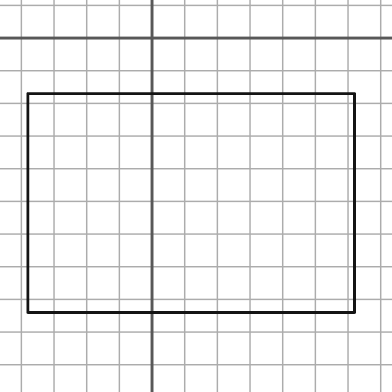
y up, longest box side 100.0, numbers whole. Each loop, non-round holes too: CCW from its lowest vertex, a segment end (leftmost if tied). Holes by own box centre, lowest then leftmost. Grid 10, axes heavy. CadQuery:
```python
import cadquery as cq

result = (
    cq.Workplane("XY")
    .moveTo(-38.0, -84.0)
    .lineTo(62.0, -84.0)
    .lineTo(62.0, -17.0)
    .lineTo(-38.0, -17.0)
    .close()
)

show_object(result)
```